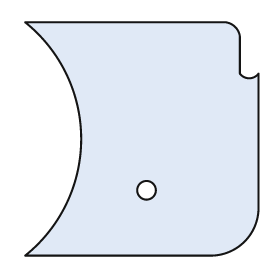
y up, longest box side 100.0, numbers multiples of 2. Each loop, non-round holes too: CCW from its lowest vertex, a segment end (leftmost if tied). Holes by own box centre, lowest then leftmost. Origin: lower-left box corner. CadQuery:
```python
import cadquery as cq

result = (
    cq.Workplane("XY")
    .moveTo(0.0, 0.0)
    .lineTo(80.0, 0.0)
    .threePointArc((94.0, 6.0), (100.0, 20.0))
    .lineTo(100.0, 78.0)
    .threePointArc((96.0, 76.0), (92.0, 78.0))
    .lineTo(92.0, 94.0)
    .threePointArc((90.0, 98.0), (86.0, 100.0))
    .lineTo(0.0, 100.0)
    .threePointArc((24.0, 50.0), (0.0, 0.0))
    .close()
    .moveTo(52.0, 28.0)
    .circle(4.0)
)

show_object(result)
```